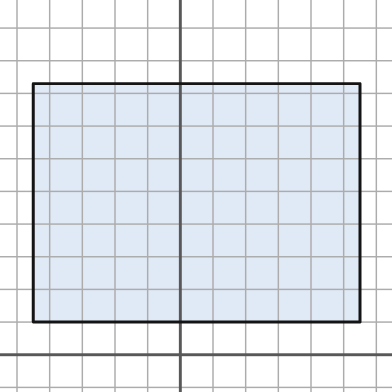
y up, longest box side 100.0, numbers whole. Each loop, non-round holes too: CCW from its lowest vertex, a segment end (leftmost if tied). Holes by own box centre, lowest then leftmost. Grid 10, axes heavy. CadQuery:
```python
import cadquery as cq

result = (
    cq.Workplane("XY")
    .moveTo(-45.0, 10.0)
    .lineTo(55.0, 10.0)
    .lineTo(55.0, 83.0)
    .lineTo(-45.0, 83.0)
    .close()
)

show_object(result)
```